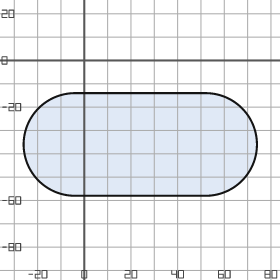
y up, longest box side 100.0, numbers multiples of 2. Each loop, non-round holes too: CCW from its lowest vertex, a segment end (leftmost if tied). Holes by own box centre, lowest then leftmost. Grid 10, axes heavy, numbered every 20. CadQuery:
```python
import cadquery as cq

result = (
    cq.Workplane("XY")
    .moveTo(-4.0, -58.0)
    .lineTo(52.0, -58.0)
    .threePointArc((74.0, -36.0), (52.0, -14.0))
    .lineTo(-4.0, -14.0)
    .threePointArc((-26.0, -36.0), (-4.0, -58.0))
    .close()
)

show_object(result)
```